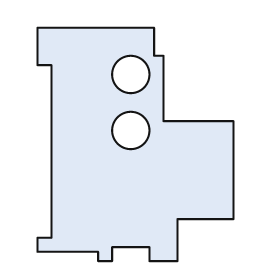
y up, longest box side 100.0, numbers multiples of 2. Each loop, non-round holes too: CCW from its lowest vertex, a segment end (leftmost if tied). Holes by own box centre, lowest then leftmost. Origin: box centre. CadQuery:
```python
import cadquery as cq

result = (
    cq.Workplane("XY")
    .moveTo(-16.0, -50.0)
    .lineTo(-10.0, -50.0)
    .lineTo(-10.0, -44.0)
    .lineTo(6.0, -44.0)
    .lineTo(6.0, -50.0)
    .lineTo(18.0, -50.0)
    .lineTo(18.0, -32.0)
    .lineTo(42.0, -32.0)
    .lineTo(42.0, 10.0)
    .lineTo(12.0, 10.0)
    .lineTo(12.0, 38.0)
    .lineTo(8.0, 38.0)
    .lineTo(8.0, 50.0)
    .lineTo(-42.0, 50.0)
    .lineTo(-42.0, 34.0)
    .lineTo(-36.0, 34.0)
    .lineTo(-36.0, -40.0)
    .lineTo(-42.0, -40.0)
    .lineTo(-42.0, -46.0)
    .lineTo(-16.0, -46.0)
    .close()
    .moveTo(-2.0, 6.0)
    .circle(8.0)
    .moveTo(-2.0, 30.0)
    .circle(8.0)
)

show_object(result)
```